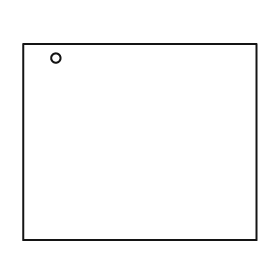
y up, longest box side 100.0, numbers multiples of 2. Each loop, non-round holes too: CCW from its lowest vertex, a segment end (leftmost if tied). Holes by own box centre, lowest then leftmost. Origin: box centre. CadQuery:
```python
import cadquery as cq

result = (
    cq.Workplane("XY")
    .moveTo(-50.0, -42.0)
    .lineTo(50.0, -42.0)
    .lineTo(50.0, 42.0)
    .lineTo(-50.0, 42.0)
    .close()
    .moveTo(-36.0, 36.0)
    .circle(2.0)
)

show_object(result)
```